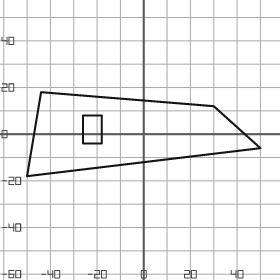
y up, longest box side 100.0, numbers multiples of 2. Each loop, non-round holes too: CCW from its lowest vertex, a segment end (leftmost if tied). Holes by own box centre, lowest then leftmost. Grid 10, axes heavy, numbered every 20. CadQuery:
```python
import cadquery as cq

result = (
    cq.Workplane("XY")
    .moveTo(-50.0, -18.0)
    .lineTo(50.0, -6.0)
    .lineTo(30.0, 12.0)
    .lineTo(-44.0, 18.0)
    .close()
    .moveTo(-26.0, -4.0)
    .lineTo(-18.0, -4.0)
    .lineTo(-18.0, 8.0)
    .lineTo(-26.0, 8.0)
    .close()
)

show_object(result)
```